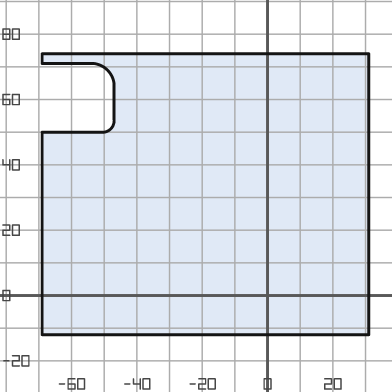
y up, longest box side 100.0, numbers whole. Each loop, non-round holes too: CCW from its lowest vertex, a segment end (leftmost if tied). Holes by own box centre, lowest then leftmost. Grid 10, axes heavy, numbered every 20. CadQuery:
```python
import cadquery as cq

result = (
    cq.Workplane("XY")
    .moveTo(-69.0, -12.0)
    .lineTo(31.0, -12.0)
    .lineTo(31.0, 74.0)
    .lineTo(-69.0, 74.0)
    .lineTo(-69.0, 71.0)
    .lineTo(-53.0, 71.0)
    .threePointArc((-49.0, 69.0), (-47.0, 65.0))
    .lineTo(-47.0, 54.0)
    .threePointArc((-48.0, 51.0), (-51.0, 50.0))
    .lineTo(-69.0, 50.0)
    .close()
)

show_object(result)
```